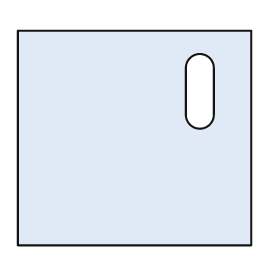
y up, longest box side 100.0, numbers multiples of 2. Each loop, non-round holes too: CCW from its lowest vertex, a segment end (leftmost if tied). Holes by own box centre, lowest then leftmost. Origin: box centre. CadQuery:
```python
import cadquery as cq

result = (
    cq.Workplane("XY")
    .moveTo(-50.0, -46.0)
    .lineTo(50.0, -46.0)
    .lineTo(50.0, 46.0)
    .lineTo(-50.0, 46.0)
    .close()
    .moveTo(22.0, 10.0)
    .threePointArc((28.0, 4.0), (34.0, 10.0))
    .lineTo(34.0, 30.0)
    .threePointArc((28.0, 36.0), (22.0, 30.0))
    .close()
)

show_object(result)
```